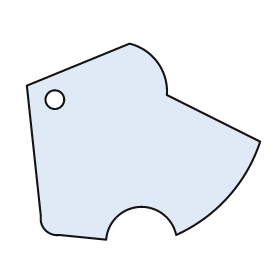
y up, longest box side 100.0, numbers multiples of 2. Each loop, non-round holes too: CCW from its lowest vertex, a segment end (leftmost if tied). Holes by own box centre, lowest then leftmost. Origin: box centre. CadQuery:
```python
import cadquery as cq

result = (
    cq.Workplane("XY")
    .moveTo(-16.0, -42.0)
    .threePointArc((-2.0, -28.0), (14.0, -40.0))
    .threePointArc((36.0, -24.0), (50.0, 0.0))
    .lineTo(10.0, 20.0)
    .threePointArc((6.0, 34.0), (-6.0, 42.0))
    .lineTo(-50.0, 24.0)
    .lineTo(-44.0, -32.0)
    .threePointArc((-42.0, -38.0), (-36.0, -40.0))
    .close()
    .moveTo(-38.0, 18.0)
    .circle(4.0)
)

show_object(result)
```